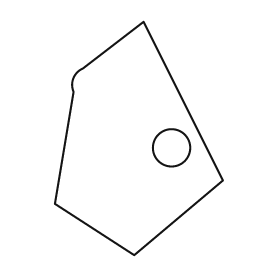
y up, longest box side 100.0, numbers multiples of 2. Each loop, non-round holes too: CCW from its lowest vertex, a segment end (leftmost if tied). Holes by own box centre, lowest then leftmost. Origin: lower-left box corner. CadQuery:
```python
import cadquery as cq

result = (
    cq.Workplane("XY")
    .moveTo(34.0, 0.0)
    .lineTo(72.0, 32.0)
    .lineTo(38.0, 100.0)
    .lineTo(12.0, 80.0)
    .threePointArc((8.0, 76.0), (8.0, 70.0))
    .lineTo(0.0, 22.0)
    .close()
    .moveTo(50.0, 46.0)
    .circle(8.0)
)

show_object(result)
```